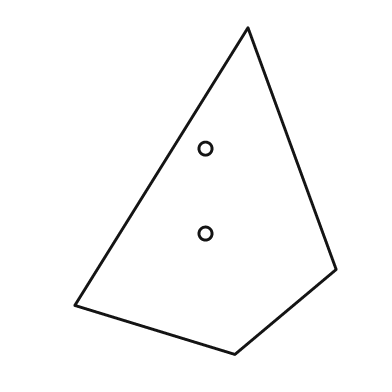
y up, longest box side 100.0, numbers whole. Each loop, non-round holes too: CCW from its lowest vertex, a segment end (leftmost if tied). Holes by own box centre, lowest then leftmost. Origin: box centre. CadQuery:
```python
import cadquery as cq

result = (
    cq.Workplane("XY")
    .moveTo(9.0, -50.0)
    .lineTo(40.0, -24.0)
    .lineTo(13.0, 50.0)
    .lineTo(-40.0, -35.0)
    .close()
    .moveTo(0.0, -13.0)
    .circle(2.0)
    .moveTo(0.0, 13.0)
    .circle(2.0)
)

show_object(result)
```